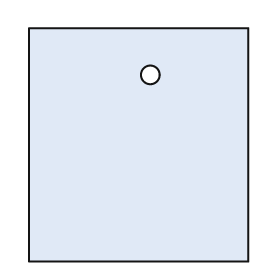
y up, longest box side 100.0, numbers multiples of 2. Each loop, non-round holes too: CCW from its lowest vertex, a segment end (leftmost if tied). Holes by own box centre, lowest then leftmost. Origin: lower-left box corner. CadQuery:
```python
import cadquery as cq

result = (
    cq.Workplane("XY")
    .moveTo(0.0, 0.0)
    .lineTo(94.0, 0.0)
    .lineTo(94.0, 100.0)
    .lineTo(0.0, 100.0)
    .close()
    .moveTo(52.0, 80.0)
    .circle(4.0)
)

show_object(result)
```